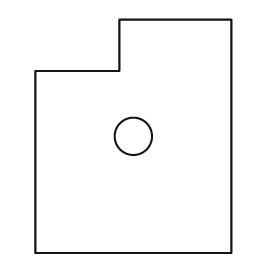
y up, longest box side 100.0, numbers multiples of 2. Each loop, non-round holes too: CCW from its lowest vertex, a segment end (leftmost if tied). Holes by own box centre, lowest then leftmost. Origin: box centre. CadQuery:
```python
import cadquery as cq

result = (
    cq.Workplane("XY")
    .moveTo(-42.0, -50.0)
    .lineTo(42.0, -50.0)
    .lineTo(42.0, 50.0)
    .lineTo(-6.0, 50.0)
    .lineTo(-6.0, 28.0)
    .lineTo(-42.0, 28.0)
    .close()
    .moveTo(0.0, 0.0)
    .circle(8.0)
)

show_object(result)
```